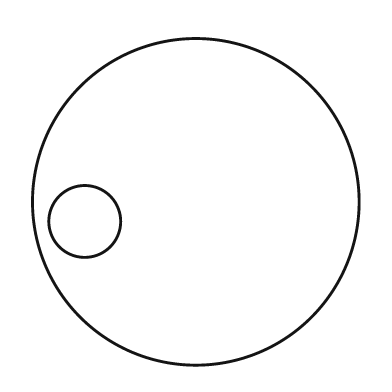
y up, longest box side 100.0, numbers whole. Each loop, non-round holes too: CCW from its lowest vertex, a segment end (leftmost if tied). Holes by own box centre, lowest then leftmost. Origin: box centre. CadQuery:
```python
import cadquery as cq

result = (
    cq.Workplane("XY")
    .moveTo(0.0, 0.0)
    .circle(50.0)
    .moveTo(-34.0, -6.0)
    .circle(11.0)
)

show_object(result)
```